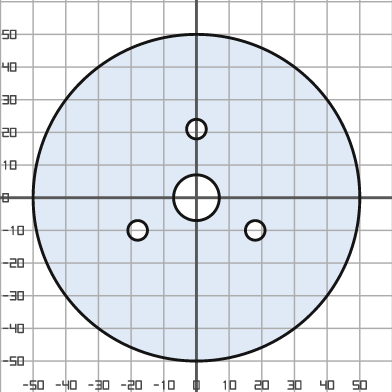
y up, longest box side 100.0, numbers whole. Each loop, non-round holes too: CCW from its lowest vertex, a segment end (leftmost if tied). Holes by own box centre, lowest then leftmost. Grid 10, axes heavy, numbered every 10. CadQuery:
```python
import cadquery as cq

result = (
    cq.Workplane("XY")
    .moveTo(0.0, 0.0)
    .circle(50.0)
    .moveTo(-18.0, -10.0)
    .circle(3.0)
    .moveTo(18.0, -10.0)
    .circle(3.0)
    .moveTo(0.0, 0.0)
    .circle(7.0)
    .moveTo(0.0, 21.0)
    .circle(3.0)
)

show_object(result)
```